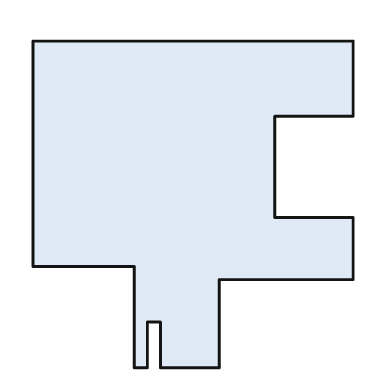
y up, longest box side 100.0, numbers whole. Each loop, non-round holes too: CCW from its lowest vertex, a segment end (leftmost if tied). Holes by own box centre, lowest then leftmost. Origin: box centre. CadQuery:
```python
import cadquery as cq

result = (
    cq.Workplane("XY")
    .moveTo(-18.0, -50.0)
    .lineTo(-14.0, -50.0)
    .lineTo(-14.0, -36.0)
    .lineTo(-10.0, -36.0)
    .lineTo(-10.0, -50.0)
    .lineTo(8.0, -50.0)
    .lineTo(8.0, -23.0)
    .lineTo(49.0, -23.0)
    .lineTo(49.0, -4.0)
    .lineTo(25.0, -4.0)
    .lineTo(25.0, 27.0)
    .lineTo(49.0, 27.0)
    .lineTo(49.0, 50.0)
    .lineTo(-49.0, 50.0)
    .lineTo(-49.0, -19.0)
    .lineTo(-18.0, -19.0)
    .close()
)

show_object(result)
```